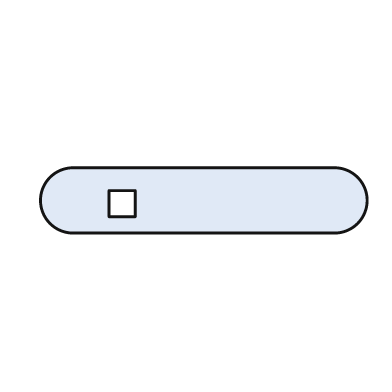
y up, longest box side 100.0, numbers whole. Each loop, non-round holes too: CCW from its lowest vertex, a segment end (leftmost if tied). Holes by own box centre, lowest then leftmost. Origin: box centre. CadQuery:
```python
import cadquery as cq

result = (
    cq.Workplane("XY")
    .moveTo(-40.0, -10.0)
    .lineTo(40.0, -10.0)
    .threePointArc((50.0, 0.0), (40.0, 10.0))
    .lineTo(-40.0, 10.0)
    .threePointArc((-50.0, 0.0), (-40.0, -10.0))
    .close()
    .moveTo(-29.0, -5.0)
    .lineTo(-21.0, -5.0)
    .lineTo(-21.0, 3.0)
    .lineTo(-29.0, 3.0)
    .close()
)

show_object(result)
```